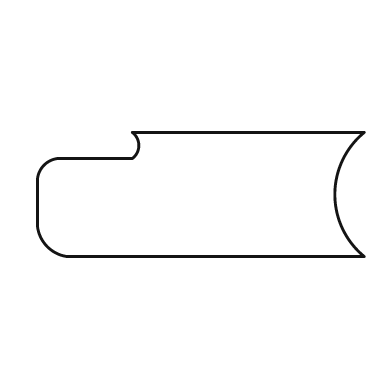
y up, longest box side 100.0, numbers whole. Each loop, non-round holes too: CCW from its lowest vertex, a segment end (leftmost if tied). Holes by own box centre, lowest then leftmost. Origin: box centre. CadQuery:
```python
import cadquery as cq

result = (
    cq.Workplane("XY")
    .moveTo(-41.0, -19.0)
    .lineTo(50.0, -19.0)
    .threePointArc((41.0, 0.0), (50.0, 19.0))
    .lineTo(-21.0, 19.0)
    .threePointArc((-19.0, 15.0), (-21.0, 11.0))
    .lineTo(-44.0, 11.0)
    .threePointArc((-48.0, 9.0), (-50.0, 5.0))
    .lineTo(-50.0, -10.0)
    .threePointArc((-47.0, -16.0), (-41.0, -19.0))
    .close()
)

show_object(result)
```